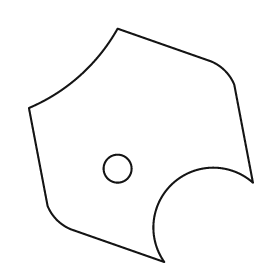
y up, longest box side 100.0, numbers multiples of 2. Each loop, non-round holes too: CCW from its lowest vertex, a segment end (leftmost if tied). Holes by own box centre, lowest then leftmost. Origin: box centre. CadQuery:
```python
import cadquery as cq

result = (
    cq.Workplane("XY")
    .moveTo(10.0, -50.0)
    .threePointArc((14.0, -16.0), (48.0, -16.0))
    .lineTo(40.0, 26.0)
    .threePointArc((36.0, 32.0), (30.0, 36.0))
    .lineTo(-10.0, 50.0)
    .threePointArc((-26.0, 30.0), (-48.0, 16.0))
    .lineTo(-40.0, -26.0)
    .threePointArc((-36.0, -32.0), (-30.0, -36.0))
    .close()
    .moveTo(-10.0, -10.0)
    .circle(6.0)
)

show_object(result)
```